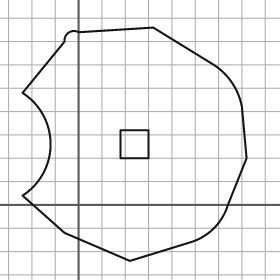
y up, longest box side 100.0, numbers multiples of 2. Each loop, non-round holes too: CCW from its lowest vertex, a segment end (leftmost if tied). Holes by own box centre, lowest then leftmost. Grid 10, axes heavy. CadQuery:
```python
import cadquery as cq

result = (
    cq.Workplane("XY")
    .moveTo(22.0, -24.0)
    .lineTo(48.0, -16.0)
    .threePointArc((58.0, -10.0), (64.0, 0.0))
    .lineTo(72.0, 20.0)
    .lineTo(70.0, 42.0)
    .threePointArc((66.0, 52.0), (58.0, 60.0))
    .lineTo(32.0, 76.0)
    .lineTo(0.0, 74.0)
    .threePointArc((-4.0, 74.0), (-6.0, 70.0))
    .lineTo(-24.0, 48.0)
    .threePointArc((-12.0, 26.0), (-24.0, 4.0))
    .lineTo(-6.0, -12.0)
    .close()
    .moveTo(18.0, 20.0)
    .lineTo(30.0, 20.0)
    .lineTo(30.0, 32.0)
    .lineTo(18.0, 32.0)
    .close()
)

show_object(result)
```